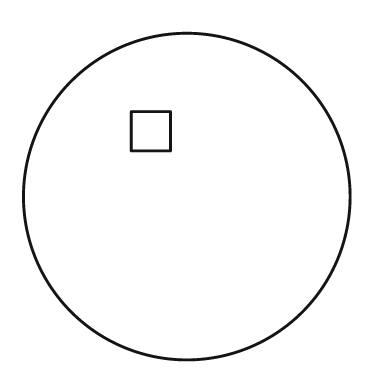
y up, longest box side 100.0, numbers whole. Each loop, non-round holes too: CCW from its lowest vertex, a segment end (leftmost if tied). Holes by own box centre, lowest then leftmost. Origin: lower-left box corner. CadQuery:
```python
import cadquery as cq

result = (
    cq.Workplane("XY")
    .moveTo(50.0, 50.0)
    .circle(50.0)
    .moveTo(33.0, 64.0)
    .lineTo(45.0, 64.0)
    .lineTo(45.0, 76.0)
    .lineTo(33.0, 76.0)
    .close()
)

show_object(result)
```